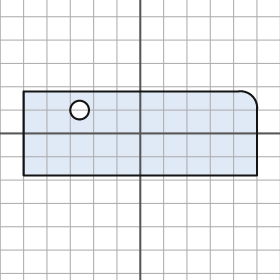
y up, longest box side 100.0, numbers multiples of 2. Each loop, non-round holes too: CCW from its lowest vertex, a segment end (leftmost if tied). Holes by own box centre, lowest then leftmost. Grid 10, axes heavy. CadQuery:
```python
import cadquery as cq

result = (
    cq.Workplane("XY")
    .moveTo(-50.0, -18.0)
    .lineTo(50.0, -18.0)
    .lineTo(50.0, 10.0)
    .threePointArc((48.0, 16.0), (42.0, 18.0))
    .lineTo(-50.0, 18.0)
    .close()
    .moveTo(-26.0, 10.0)
    .circle(4.0)
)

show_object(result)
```